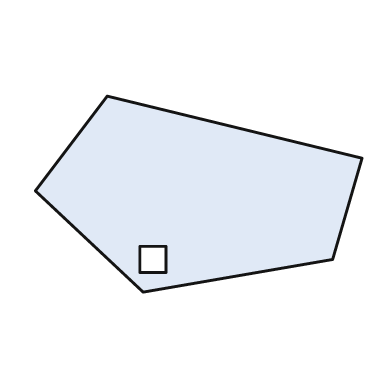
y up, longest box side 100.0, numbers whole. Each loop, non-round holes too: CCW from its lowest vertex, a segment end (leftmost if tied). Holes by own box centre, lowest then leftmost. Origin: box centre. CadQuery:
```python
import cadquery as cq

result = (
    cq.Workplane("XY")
    .moveTo(-17.0, -30.0)
    .lineTo(41.0, -20.0)
    .lineTo(50.0, 11.0)
    .lineTo(-28.0, 30.0)
    .lineTo(-50.0, 1.0)
    .close()
    .moveTo(-18.0, -24.0)
    .lineTo(-10.0, -24.0)
    .lineTo(-10.0, -16.0)
    .lineTo(-18.0, -16.0)
    .close()
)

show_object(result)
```